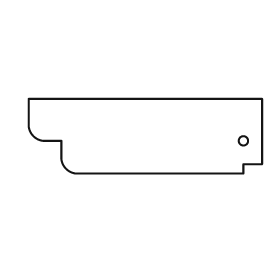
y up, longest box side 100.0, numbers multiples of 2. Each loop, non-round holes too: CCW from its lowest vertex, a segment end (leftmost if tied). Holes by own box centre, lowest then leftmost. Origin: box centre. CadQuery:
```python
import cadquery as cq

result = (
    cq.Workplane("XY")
    .moveTo(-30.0, -16.0)
    .lineTo(42.0, -16.0)
    .lineTo(42.0, -12.0)
    .lineTo(50.0, -12.0)
    .lineTo(50.0, 16.0)
    .lineTo(-50.0, 16.0)
    .lineTo(-50.0, 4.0)
    .threePointArc((-48.0, 0.0), (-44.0, -2.0))
    .lineTo(-36.0, -2.0)
    .lineTo(-36.0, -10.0)
    .threePointArc((-34.0, -14.0), (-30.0, -16.0))
    .close()
    .moveTo(42.0, -2.0)
    .circle(2.0)
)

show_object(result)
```